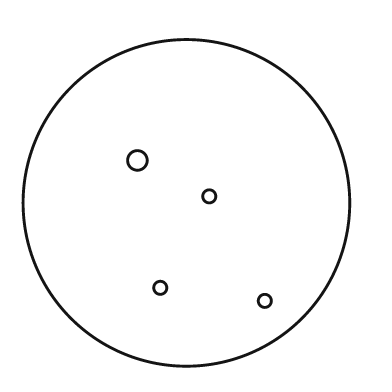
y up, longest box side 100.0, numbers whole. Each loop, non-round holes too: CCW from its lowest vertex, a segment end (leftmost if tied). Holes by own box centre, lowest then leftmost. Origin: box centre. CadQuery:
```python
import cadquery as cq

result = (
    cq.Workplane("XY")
    .moveTo(0.0, 0.0)
    .circle(50.0)
    .moveTo(24.0, -30.0)
    .circle(2.0)
    .moveTo(-8.0, -26.0)
    .circle(2.0)
    .moveTo(7.0, 2.0)
    .circle(2.0)
    .moveTo(-15.0, 13.0)
    .circle(3.0)
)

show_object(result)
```